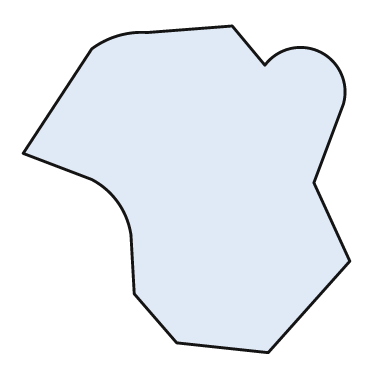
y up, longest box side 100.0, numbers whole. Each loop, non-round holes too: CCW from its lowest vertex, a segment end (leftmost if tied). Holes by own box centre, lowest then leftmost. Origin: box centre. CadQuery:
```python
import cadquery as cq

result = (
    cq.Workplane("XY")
    .moveTo(25.0, -50.0)
    .lineTo(50.0, -22.0)
    .lineTo(39.0, 2.0)
    .lineTo(48.0, 26.0)
    .threePointArc((41.0, 42.0), (24.0, 38.0))
    .lineTo(14.0, 50.0)
    .lineTo(-12.0, 48.0)
    .threePointArc((-21.0, 47.0), (-29.0, 43.0))
    .lineTo(-50.0, 11.0)
    .lineTo(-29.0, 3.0)
    .threePointArc((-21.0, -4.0), (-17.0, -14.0))
    .lineTo(-16.0, -32.0)
    .lineTo(-3.0, -47.0)
    .close()
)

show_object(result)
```